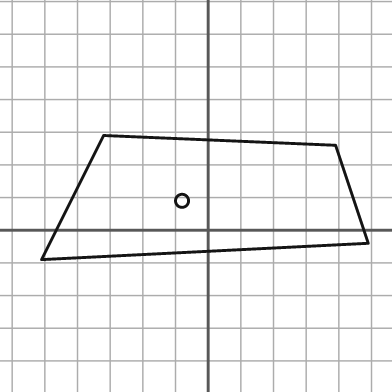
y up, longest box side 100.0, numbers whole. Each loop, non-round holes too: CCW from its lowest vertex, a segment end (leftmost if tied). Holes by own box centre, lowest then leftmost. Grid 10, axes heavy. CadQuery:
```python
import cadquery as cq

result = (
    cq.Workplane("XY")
    .moveTo(-51.0, -9.0)
    .lineTo(49.0, -4.0)
    .lineTo(39.0, 26.0)
    .lineTo(-32.0, 29.0)
    .close()
    .moveTo(-8.0, 9.0)
    .circle(2.0)
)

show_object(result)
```